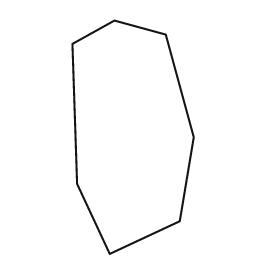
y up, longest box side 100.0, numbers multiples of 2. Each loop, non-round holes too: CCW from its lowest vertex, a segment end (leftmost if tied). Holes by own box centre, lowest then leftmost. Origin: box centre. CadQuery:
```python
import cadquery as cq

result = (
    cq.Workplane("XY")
    .moveTo(-10.0, -50.0)
    .lineTo(20.0, -36.0)
    .lineTo(26.0, 0.0)
    .lineTo(14.0, 44.0)
    .lineTo(-8.0, 50.0)
    .lineTo(-26.0, 40.0)
    .lineTo(-24.0, -20.0)
    .close()
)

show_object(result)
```